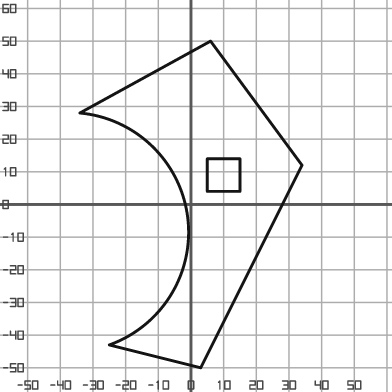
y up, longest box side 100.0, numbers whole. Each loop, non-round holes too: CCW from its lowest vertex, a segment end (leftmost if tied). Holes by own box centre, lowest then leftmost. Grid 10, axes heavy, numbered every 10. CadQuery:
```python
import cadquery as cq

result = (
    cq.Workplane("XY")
    .moveTo(3.0, -50.0)
    .lineTo(34.0, 12.0)
    .lineTo(6.0, 50.0)
    .lineTo(-34.0, 28.0)
    .threePointArc((-1.0, -4.0), (-25.0, -43.0))
    .close()
    .moveTo(5.0, 4.0)
    .lineTo(15.0, 4.0)
    .lineTo(15.0, 14.0)
    .lineTo(5.0, 14.0)
    .close()
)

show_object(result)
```